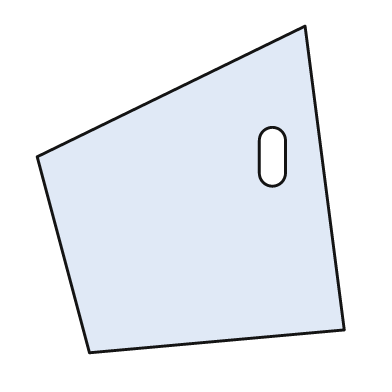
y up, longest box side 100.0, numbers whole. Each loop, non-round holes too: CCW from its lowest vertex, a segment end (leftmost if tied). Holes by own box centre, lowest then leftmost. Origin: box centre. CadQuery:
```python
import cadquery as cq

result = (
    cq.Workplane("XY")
    .moveTo(-31.0, -50.0)
    .lineTo(47.0, -43.0)
    .lineTo(35.0, 50.0)
    .lineTo(-47.0, 10.0)
    .close()
    .moveTo(21.0, 5.0)
    .threePointArc((25.0, 1.0), (29.0, 5.0))
    .lineTo(29.0, 15.0)
    .threePointArc((25.0, 19.0), (21.0, 15.0))
    .close()
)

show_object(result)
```